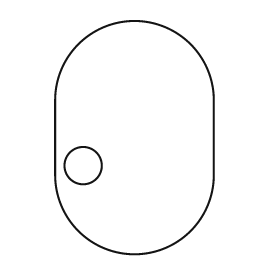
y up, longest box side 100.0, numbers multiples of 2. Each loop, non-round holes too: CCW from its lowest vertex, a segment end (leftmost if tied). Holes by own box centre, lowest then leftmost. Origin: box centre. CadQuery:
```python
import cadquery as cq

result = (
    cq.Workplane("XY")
    .moveTo(-34.0, -16.0)
    .threePointArc((0.0, -50.0), (34.0, -16.0))
    .lineTo(34.0, 16.0)
    .threePointArc((0.0, 50.0), (-34.0, 16.0))
    .close()
    .moveTo(-22.0, -12.0)
    .circle(8.0)
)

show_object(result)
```